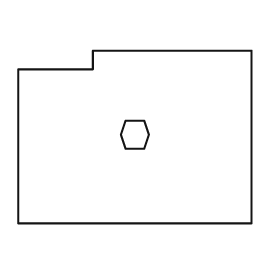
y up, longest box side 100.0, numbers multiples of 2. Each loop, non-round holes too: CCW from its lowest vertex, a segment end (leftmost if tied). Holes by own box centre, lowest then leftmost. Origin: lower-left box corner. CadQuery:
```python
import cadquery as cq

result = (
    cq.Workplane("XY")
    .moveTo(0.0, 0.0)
    .lineTo(100.0, 0.0)
    .lineTo(100.0, 74.0)
    .lineTo(32.0, 74.0)
    .lineTo(32.0, 66.0)
    .lineTo(0.0, 66.0)
    .close()
    .moveTo(46.0, 32.0)
    .lineTo(54.0, 32.0)
    .lineTo(56.0, 38.0)
    .lineTo(54.0, 44.0)
    .lineTo(46.0, 44.0)
    .lineTo(44.0, 38.0)
    .close()
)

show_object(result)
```